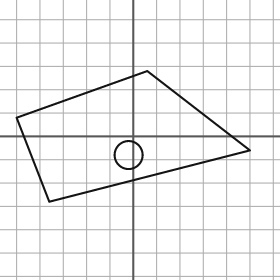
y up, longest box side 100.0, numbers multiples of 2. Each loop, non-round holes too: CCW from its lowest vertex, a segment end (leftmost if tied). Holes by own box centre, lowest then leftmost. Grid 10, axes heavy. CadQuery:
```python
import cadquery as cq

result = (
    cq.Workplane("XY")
    .moveTo(-36.0, -28.0)
    .lineTo(50.0, -6.0)
    .lineTo(6.0, 28.0)
    .lineTo(-50.0, 8.0)
    .close()
    .moveTo(-2.0, -8.0)
    .circle(6.0)
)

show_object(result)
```